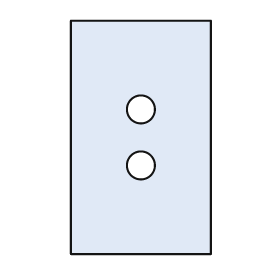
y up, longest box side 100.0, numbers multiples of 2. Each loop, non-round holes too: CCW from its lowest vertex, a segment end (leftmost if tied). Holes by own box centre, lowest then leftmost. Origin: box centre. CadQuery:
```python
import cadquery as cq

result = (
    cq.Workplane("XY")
    .moveTo(-30.0, -50.0)
    .lineTo(30.0, -50.0)
    .lineTo(30.0, 50.0)
    .lineTo(-30.0, 50.0)
    .close()
    .moveTo(0.0, -12.0)
    .circle(6.0)
    .moveTo(0.0, 12.0)
    .circle(6.0)
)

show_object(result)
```